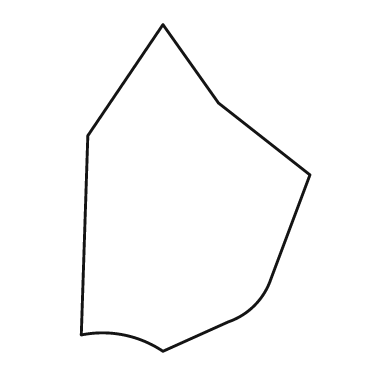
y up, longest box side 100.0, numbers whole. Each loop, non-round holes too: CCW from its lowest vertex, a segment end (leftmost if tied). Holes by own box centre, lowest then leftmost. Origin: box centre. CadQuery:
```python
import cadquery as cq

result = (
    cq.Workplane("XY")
    .moveTo(-10.0, -50.0)
    .lineTo(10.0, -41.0)
    .threePointArc((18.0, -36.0), (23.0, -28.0))
    .lineTo(35.0, 4.0)
    .lineTo(7.0, 26.0)
    .lineTo(-10.0, 50.0)
    .lineTo(-33.0, 16.0)
    .lineTo(-35.0, -45.0)
    .threePointArc((-22.0, -45.0), (-10.0, -50.0))
    .close()
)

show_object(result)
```